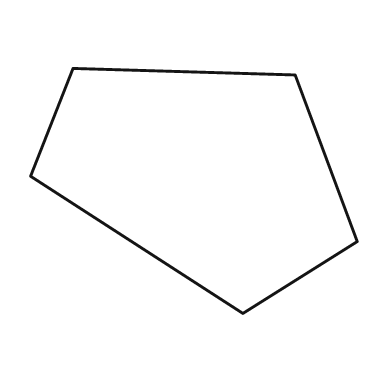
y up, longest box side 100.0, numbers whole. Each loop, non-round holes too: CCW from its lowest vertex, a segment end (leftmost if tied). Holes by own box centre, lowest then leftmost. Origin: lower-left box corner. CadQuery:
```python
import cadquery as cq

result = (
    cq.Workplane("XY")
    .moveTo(65.0, 0.0)
    .lineTo(100.0, 22.0)
    .lineTo(81.0, 73.0)
    .lineTo(13.0, 75.0)
    .lineTo(0.0, 42.0)
    .close()
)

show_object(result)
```